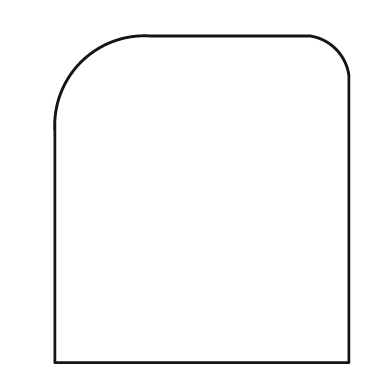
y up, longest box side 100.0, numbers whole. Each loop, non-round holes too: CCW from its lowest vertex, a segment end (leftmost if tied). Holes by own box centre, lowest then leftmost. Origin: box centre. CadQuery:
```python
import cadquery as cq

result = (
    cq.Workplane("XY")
    .moveTo(-45.0, -50.0)
    .lineTo(45.0, -50.0)
    .lineTo(45.0, 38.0)
    .threePointArc((41.0, 46.0), (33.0, 50.0))
    .lineTo(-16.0, 50.0)
    .threePointArc((-37.0, 42.0), (-45.0, 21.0))
    .close()
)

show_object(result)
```